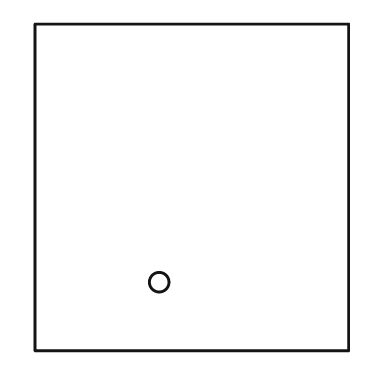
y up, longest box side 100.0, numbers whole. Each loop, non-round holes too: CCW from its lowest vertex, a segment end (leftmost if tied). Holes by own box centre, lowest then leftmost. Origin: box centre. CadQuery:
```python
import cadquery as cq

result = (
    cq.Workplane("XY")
    .moveTo(-48.0, -50.0)
    .lineTo(48.0, -50.0)
    .lineTo(48.0, 50.0)
    .lineTo(-48.0, 50.0)
    .close()
    .moveTo(-10.0, -29.0)
    .circle(3.0)
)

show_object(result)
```